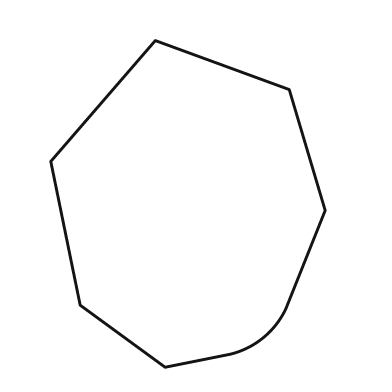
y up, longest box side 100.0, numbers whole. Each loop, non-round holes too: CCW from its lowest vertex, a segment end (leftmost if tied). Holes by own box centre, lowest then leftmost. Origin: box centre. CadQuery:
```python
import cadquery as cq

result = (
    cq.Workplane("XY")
    .moveTo(-7.0, -50.0)
    .lineTo(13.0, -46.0)
    .threePointArc((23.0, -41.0), (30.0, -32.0))
    .lineTo(42.0, -2.0)
    .lineTo(31.0, 35.0)
    .lineTo(-10.0, 50.0)
    .lineTo(-42.0, 13.0)
    .lineTo(-33.0, -31.0)
    .close()
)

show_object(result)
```